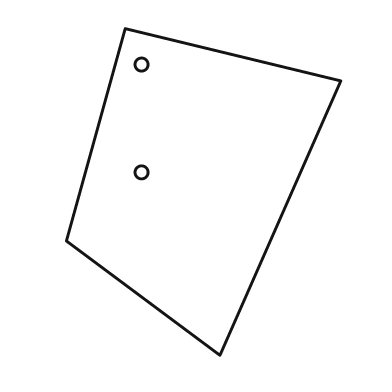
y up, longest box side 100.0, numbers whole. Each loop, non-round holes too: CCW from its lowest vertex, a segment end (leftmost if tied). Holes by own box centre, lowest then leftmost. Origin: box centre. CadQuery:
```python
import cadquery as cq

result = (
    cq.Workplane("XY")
    .moveTo(5.0, -50.0)
    .lineTo(42.0, 34.0)
    .lineTo(-24.0, 50.0)
    .lineTo(-42.0, -15.0)
    .close()
    .moveTo(-19.0, 6.0)
    .circle(2.0)
    .moveTo(-19.0, 39.0)
    .circle(2.0)
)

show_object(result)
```